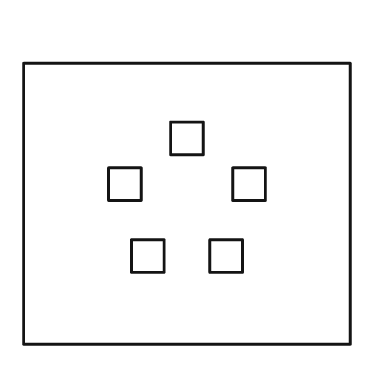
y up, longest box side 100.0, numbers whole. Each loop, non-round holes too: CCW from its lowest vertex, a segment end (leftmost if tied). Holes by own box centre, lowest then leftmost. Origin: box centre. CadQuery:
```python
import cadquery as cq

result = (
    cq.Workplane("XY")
    .moveTo(-50.0, -43.0)
    .lineTo(50.0, -43.0)
    .lineTo(50.0, 43.0)
    .lineTo(-50.0, 43.0)
    .close()
    .moveTo(-17.0, -21.0)
    .lineTo(-7.0, -21.0)
    .lineTo(-7.0, -11.0)
    .lineTo(-17.0, -11.0)
    .close()
    .moveTo(7.0, -21.0)
    .lineTo(17.0, -21.0)
    .lineTo(17.0, -11.0)
    .lineTo(7.0, -11.0)
    .close()
    .moveTo(-24.0, 1.0)
    .lineTo(-14.0, 1.0)
    .lineTo(-14.0, 11.0)
    .lineTo(-24.0, 11.0)
    .close()
    .moveTo(14.0, 1.0)
    .lineTo(24.0, 1.0)
    .lineTo(24.0, 11.0)
    .lineTo(14.0, 11.0)
    .close()
    .moveTo(-5.0, 15.0)
    .lineTo(5.0, 15.0)
    .lineTo(5.0, 25.0)
    .lineTo(-5.0, 25.0)
    .close()
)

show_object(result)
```